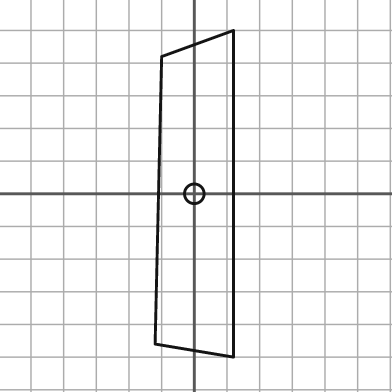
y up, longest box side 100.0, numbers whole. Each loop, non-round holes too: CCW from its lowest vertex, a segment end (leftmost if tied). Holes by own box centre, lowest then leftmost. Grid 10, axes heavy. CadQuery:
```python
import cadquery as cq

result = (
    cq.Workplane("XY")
    .moveTo(12.0, -50.0)
    .lineTo(12.0, 50.0)
    .lineTo(-10.0, 42.0)
    .lineTo(-12.0, -46.0)
    .close()
    .moveTo(0.0, 0.0)
    .circle(3.0)
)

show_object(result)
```